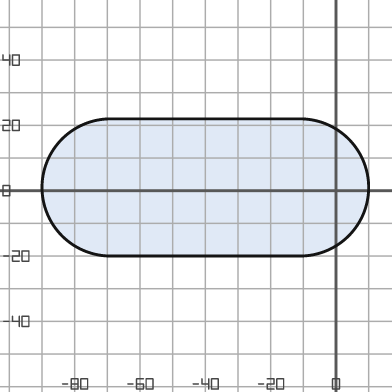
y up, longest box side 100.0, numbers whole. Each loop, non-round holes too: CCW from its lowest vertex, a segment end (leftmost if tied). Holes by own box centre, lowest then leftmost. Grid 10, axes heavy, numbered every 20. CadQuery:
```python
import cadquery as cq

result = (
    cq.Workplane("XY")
    .moveTo(-69.0, -20.0)
    .lineTo(-11.0, -20.0)
    .threePointArc((10.0, 1.0), (-11.0, 22.0))
    .lineTo(-69.0, 22.0)
    .threePointArc((-90.0, 1.0), (-69.0, -20.0))
    .close()
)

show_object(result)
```